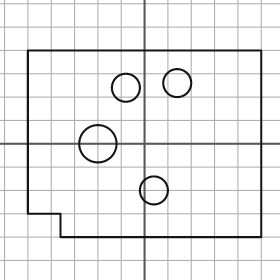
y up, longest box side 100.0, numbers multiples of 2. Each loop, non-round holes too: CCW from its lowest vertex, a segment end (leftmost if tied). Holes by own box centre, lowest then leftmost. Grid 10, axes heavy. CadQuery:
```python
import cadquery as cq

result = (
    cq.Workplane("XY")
    .moveTo(-36.0, -40.0)
    .lineTo(50.0, -40.0)
    .lineTo(50.0, 40.0)
    .lineTo(-50.0, 40.0)
    .lineTo(-50.0, -30.0)
    .lineTo(-36.0, -30.0)
    .close()
    .moveTo(4.0, -20.0)
    .circle(6.0)
    .moveTo(-20.0, 0.0)
    .circle(8.0)
    .moveTo(-8.0, 24.0)
    .circle(6.0)
    .moveTo(14.0, 26.0)
    .circle(6.0)
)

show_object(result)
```